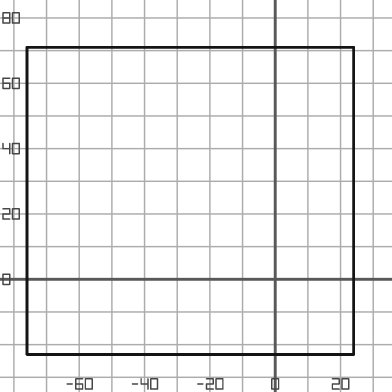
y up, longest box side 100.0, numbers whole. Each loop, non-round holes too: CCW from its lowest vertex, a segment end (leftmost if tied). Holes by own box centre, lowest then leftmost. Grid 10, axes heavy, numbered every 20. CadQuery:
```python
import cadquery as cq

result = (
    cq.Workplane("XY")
    .moveTo(-76.0, -23.0)
    .lineTo(24.0, -23.0)
    .lineTo(24.0, 71.0)
    .lineTo(-76.0, 71.0)
    .close()
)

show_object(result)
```